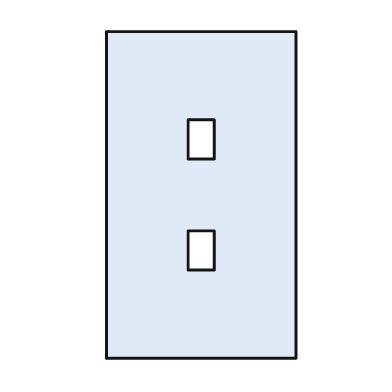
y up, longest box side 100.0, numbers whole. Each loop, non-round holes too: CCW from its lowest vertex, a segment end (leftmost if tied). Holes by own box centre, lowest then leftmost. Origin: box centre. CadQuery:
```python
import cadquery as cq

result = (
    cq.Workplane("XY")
    .moveTo(-29.0, -50.0)
    .lineTo(29.0, -50.0)
    .lineTo(29.0, 50.0)
    .lineTo(-29.0, 50.0)
    .close()
    .moveTo(-4.0, -23.0)
    .lineTo(4.0, -23.0)
    .lineTo(4.0, -11.0)
    .lineTo(-4.0, -11.0)
    .close()
    .moveTo(-4.0, 11.0)
    .lineTo(4.0, 11.0)
    .lineTo(4.0, 23.0)
    .lineTo(-4.0, 23.0)
    .close()
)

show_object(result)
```